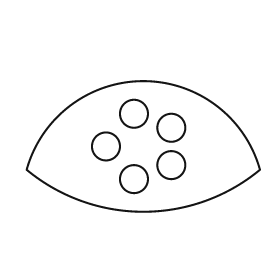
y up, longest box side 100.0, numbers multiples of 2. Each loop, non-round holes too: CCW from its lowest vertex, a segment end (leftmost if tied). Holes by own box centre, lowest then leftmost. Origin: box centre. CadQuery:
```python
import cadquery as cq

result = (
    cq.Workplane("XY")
    .moveTo(-50.0, -10.0)
    .threePointArc((0.0, -28.0), (50.0, -10.0))
    .threePointArc((0.0, 28.0), (-50.0, -10.0))
    .close()
    .moveTo(-4.0, -14.0)
    .circle(6.0)
    .moveTo(12.0, -8.0)
    .circle(6.0)
    .moveTo(-16.0, 0.0)
    .circle(6.0)
    .moveTo(12.0, 8.0)
    .circle(6.0)
    .moveTo(-4.0, 14.0)
    .circle(6.0)
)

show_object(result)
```